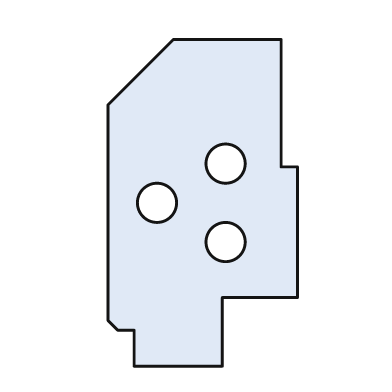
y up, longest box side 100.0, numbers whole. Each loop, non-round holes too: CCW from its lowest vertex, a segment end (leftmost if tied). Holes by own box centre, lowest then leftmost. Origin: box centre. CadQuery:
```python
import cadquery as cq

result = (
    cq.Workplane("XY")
    .moveTo(-21.0, -50.0)
    .lineTo(6.0, -50.0)
    .lineTo(6.0, -29.0)
    .lineTo(29.0, -29.0)
    .lineTo(29.0, 11.0)
    .lineTo(24.0, 11.0)
    .lineTo(24.0, 50.0)
    .lineTo(-9.0, 50.0)
    .lineTo(-29.0, 30.0)
    .lineTo(-29.0, -36.0)
    .lineTo(-26.0, -39.0)
    .lineTo(-21.0, -39.0)
    .close()
    .moveTo(7.0, -12.0)
    .circle(6.0)
    .moveTo(-14.0, 0.0)
    .circle(6.0)
    .moveTo(7.0, 12.0)
    .circle(6.0)
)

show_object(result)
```